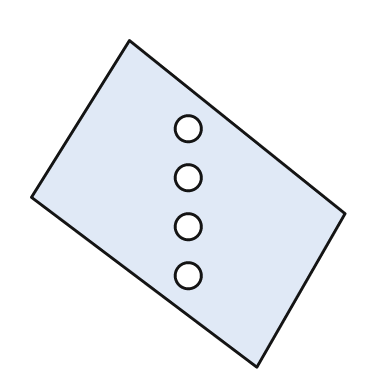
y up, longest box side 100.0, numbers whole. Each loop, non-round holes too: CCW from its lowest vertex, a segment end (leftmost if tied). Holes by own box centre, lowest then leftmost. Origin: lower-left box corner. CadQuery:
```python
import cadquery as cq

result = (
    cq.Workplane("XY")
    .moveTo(69.0, 0.0)
    .lineTo(96.0, 47.0)
    .lineTo(30.0, 100.0)
    .lineTo(0.0, 52.0)
    .close()
    .moveTo(48.0, 28.0)
    .circle(4.0)
    .moveTo(48.0, 43.0)
    .circle(4.0)
    .moveTo(48.0, 58.0)
    .circle(4.0)
    .moveTo(48.0, 73.0)
    .circle(4.0)
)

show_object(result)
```